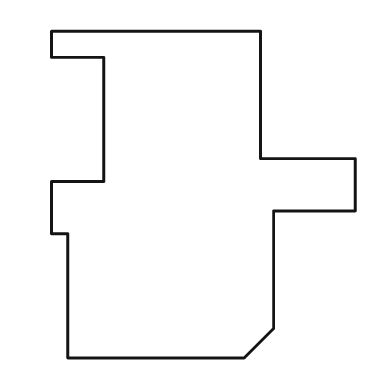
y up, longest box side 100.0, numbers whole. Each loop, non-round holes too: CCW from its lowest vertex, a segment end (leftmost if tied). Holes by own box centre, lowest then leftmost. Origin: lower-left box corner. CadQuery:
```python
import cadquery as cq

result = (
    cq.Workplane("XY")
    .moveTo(5.0, 0.0)
    .lineTo(59.0, 0.0)
    .lineTo(68.0, 9.0)
    .lineTo(68.0, 45.0)
    .lineTo(93.0, 45.0)
    .lineTo(93.0, 61.0)
    .lineTo(64.0, 61.0)
    .lineTo(64.0, 100.0)
    .lineTo(0.0, 100.0)
    .lineTo(0.0, 92.0)
    .lineTo(16.0, 92.0)
    .lineTo(16.0, 54.0)
    .lineTo(0.0, 54.0)
    .lineTo(0.0, 38.0)
    .lineTo(5.0, 38.0)
    .close()
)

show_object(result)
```